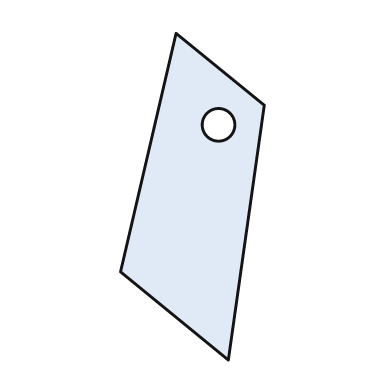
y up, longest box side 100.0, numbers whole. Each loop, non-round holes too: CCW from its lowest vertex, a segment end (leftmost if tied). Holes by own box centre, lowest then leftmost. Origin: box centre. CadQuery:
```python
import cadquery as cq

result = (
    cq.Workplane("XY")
    .moveTo(11.0, -50.0)
    .lineTo(22.0, 28.0)
    .lineTo(-5.0, 50.0)
    .lineTo(-22.0, -23.0)
    .close()
    .moveTo(8.0, 22.0)
    .circle(5.0)
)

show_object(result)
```